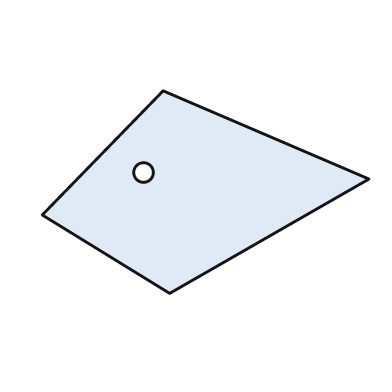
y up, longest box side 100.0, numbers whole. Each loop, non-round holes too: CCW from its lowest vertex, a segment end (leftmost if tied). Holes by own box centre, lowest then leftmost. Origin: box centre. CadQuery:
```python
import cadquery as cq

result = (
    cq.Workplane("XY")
    .moveTo(-11.0, -31.0)
    .lineTo(50.0, 4.0)
    .lineTo(-13.0, 31.0)
    .lineTo(-50.0, -7.0)
    .close()
    .moveTo(-19.0, 6.0)
    .circle(3.0)
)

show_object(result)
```